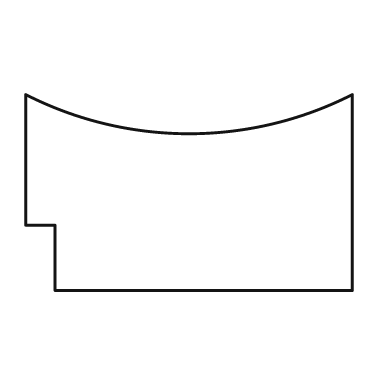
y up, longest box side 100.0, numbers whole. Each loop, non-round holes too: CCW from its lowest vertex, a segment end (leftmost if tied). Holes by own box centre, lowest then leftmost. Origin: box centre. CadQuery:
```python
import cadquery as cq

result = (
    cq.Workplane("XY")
    .moveTo(-41.0, -30.0)
    .lineTo(50.0, -30.0)
    .lineTo(50.0, 30.0)
    .threePointArc((0.0, 18.0), (-50.0, 30.0))
    .lineTo(-50.0, -10.0)
    .lineTo(-41.0, -10.0)
    .close()
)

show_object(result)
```